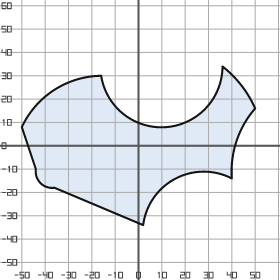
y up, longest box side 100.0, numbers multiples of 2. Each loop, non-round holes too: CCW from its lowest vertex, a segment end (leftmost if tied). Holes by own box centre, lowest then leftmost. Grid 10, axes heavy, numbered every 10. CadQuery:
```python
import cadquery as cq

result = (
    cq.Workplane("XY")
    .moveTo(2.0, -34.0)
    .threePointArc((16.0, -14.0), (40.0, -14.0))
    .threePointArc((42.0, 2.0), (50.0, 16.0))
    .threePointArc((44.0, 26.0), (36.0, 34.0))
    .threePointArc((12.0, 8.0), (-16.0, 30.0))
    .threePointArc((-36.0, 24.0), (-50.0, 8.0))
    .lineTo(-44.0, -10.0)
    .threePointArc((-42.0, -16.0), (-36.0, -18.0))
    .close()
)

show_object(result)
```